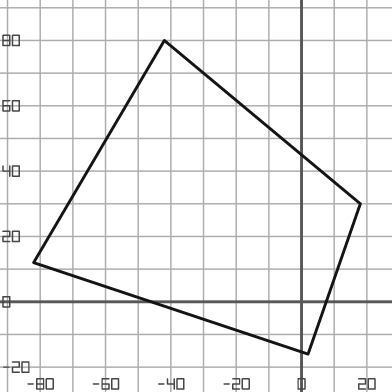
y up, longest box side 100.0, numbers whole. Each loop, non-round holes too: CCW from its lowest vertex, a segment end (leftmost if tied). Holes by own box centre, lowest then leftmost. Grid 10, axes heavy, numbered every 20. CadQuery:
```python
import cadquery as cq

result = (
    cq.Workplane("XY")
    .moveTo(2.0, -16.0)
    .lineTo(18.0, 30.0)
    .lineTo(-42.0, 80.0)
    .lineTo(-82.0, 12.0)
    .close()
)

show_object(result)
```